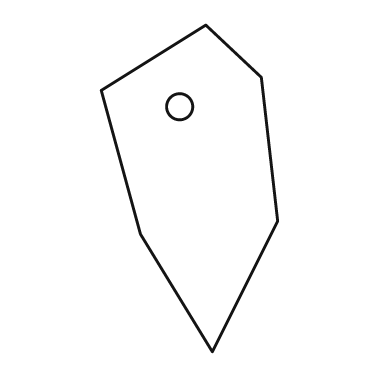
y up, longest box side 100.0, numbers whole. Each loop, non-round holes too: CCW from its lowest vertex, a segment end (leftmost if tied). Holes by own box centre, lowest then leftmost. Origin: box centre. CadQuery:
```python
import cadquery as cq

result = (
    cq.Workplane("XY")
    .moveTo(7.0, -50.0)
    .lineTo(27.0, -10.0)
    .lineTo(22.0, 34.0)
    .lineTo(5.0, 50.0)
    .lineTo(-27.0, 30.0)
    .lineTo(-15.0, -14.0)
    .close()
    .moveTo(-3.0, 25.0)
    .circle(4.0)
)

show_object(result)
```